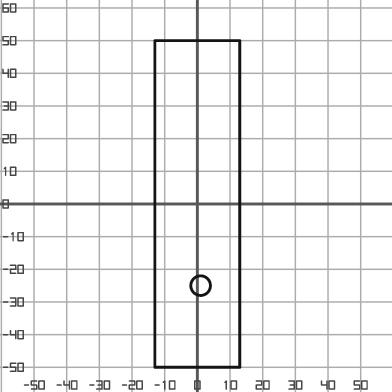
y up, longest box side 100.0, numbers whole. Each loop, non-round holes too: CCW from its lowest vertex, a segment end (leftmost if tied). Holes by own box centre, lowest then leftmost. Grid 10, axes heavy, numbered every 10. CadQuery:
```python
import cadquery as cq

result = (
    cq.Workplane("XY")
    .moveTo(-13.0, -50.0)
    .lineTo(13.0, -50.0)
    .lineTo(13.0, 50.0)
    .lineTo(-13.0, 50.0)
    .close()
    .moveTo(1.0, -25.0)
    .circle(3.0)
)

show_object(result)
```